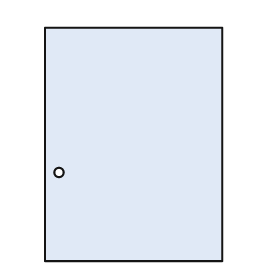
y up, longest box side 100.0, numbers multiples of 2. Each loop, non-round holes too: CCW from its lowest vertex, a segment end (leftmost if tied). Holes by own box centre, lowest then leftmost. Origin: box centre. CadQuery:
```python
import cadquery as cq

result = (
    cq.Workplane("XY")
    .moveTo(-38.0, -50.0)
    .lineTo(38.0, -50.0)
    .lineTo(38.0, 50.0)
    .lineTo(-38.0, 50.0)
    .close()
    .moveTo(-32.0, -12.0)
    .circle(2.0)
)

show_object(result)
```